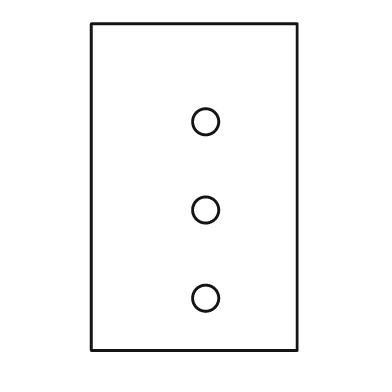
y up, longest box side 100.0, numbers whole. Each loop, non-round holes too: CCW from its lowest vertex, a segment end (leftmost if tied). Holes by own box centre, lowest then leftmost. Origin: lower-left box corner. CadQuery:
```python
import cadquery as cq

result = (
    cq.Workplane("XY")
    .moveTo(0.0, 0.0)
    .lineTo(63.0, 0.0)
    .lineTo(63.0, 100.0)
    .lineTo(0.0, 100.0)
    .close()
    .moveTo(35.0, 16.0)
    .circle(4.0)
    .moveTo(35.0, 43.0)
    .circle(4.0)
    .moveTo(35.0, 70.0)
    .circle(4.0)
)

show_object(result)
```